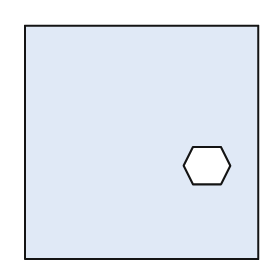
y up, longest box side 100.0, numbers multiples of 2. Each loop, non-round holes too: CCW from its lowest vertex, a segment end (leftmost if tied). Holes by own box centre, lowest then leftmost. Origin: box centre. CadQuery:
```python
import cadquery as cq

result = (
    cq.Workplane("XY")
    .moveTo(-50.0, -50.0)
    .lineTo(50.0, -50.0)
    .lineTo(50.0, 50.0)
    .lineTo(-50.0, 50.0)
    .close()
    .moveTo(22.0, -18.0)
    .lineTo(34.0, -18.0)
    .lineTo(38.0, -10.0)
    .lineTo(34.0, -2.0)
    .lineTo(22.0, -2.0)
    .lineTo(18.0, -10.0)
    .close()
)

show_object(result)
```